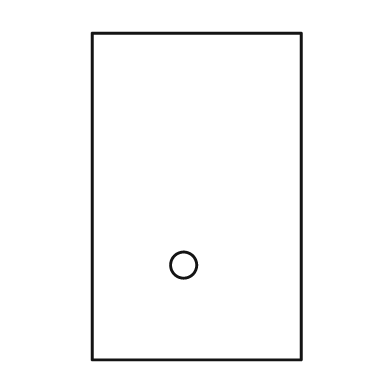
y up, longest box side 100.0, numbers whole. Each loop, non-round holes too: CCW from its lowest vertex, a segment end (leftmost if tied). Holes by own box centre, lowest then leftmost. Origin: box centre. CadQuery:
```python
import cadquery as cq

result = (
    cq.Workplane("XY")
    .moveTo(-32.0, -50.0)
    .lineTo(32.0, -50.0)
    .lineTo(32.0, 50.0)
    .lineTo(-32.0, 50.0)
    .close()
    .moveTo(-4.0, -21.0)
    .circle(4.0)
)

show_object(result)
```